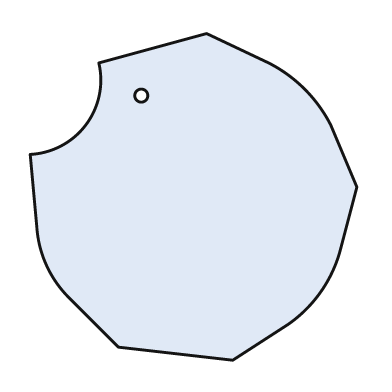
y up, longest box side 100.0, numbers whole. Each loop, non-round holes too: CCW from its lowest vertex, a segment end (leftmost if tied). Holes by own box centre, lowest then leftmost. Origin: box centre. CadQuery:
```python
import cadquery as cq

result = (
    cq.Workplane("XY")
    .moveTo(12.0, -50.0)
    .lineTo(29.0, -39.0)
    .threePointArc((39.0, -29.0), (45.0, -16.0))
    .lineTo(50.0, 3.0)
    .lineTo(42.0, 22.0)
    .threePointArc((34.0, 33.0), (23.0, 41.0))
    .lineTo(4.0, 50.0)
    .lineTo(-29.0, 41.0)
    .threePointArc((-33.0, 22.0), (-50.0, 13.0))
    .lineTo(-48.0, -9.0)
    .threePointArc((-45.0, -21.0), (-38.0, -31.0))
    .lineTo(-23.0, -46.0)
    .close()
    .moveTo(-16.0, 31.0)
    .circle(2.0)
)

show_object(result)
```